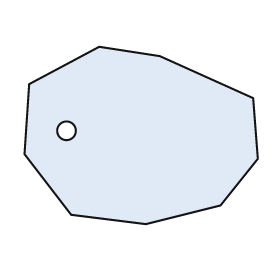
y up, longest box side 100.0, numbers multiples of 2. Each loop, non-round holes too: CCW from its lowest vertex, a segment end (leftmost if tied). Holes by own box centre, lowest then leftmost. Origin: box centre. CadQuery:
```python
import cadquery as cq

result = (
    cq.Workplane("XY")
    .moveTo(2.0, -38.0)
    .lineTo(34.0, -30.0)
    .lineTo(50.0, -10.0)
    .lineTo(48.0, 16.0)
    .lineTo(8.0, 34.0)
    .lineTo(-18.0, 38.0)
    .lineTo(-48.0, 22.0)
    .lineTo(-50.0, -8.0)
    .lineTo(-30.0, -34.0)
    .close()
    .moveTo(-32.0, 2.0)
    .circle(4.0)
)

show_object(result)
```